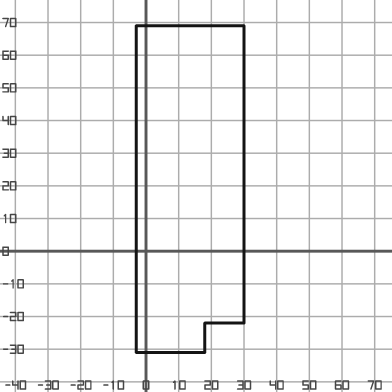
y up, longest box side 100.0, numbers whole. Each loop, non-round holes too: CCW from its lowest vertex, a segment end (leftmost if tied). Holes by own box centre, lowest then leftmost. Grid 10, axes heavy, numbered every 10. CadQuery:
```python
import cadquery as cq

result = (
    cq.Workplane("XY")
    .moveTo(-3.0, -31.0)
    .lineTo(18.0, -31.0)
    .lineTo(18.0, -22.0)
    .lineTo(30.0, -22.0)
    .lineTo(30.0, 69.0)
    .lineTo(-3.0, 69.0)
    .close()
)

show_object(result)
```